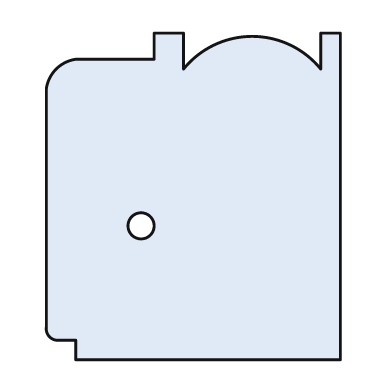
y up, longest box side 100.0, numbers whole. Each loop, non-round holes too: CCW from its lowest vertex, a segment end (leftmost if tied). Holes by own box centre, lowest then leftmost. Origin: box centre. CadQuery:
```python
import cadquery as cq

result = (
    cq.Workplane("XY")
    .moveTo(-36.0, -50.0)
    .lineTo(45.0, -50.0)
    .lineTo(45.0, 50.0)
    .lineTo(39.0, 50.0)
    .lineTo(39.0, 39.0)
    .threePointArc((18.0, 49.0), (-3.0, 39.0))
    .lineTo(-3.0, 50.0)
    .lineTo(-12.0, 50.0)
    .lineTo(-12.0, 42.0)
    .lineTo(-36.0, 42.0)
    .threePointArc((-42.0, 39.0), (-45.0, 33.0))
    .lineTo(-45.0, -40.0)
    .threePointArc((-44.0, -43.0), (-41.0, -44.0))
    .lineTo(-36.0, -44.0)
    .close()
    .moveTo(-16.0, -9.0)
    .circle(4.0)
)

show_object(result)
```